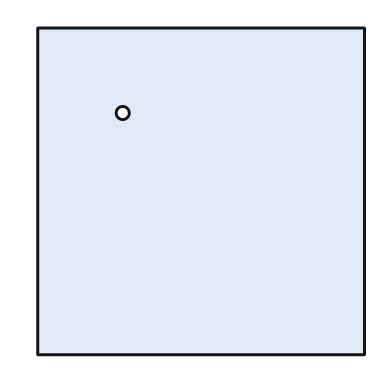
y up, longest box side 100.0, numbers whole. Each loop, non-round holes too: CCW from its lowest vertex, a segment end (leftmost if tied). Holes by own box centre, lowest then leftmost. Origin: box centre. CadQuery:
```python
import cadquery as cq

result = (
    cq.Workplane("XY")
    .moveTo(-50.0, -50.0)
    .lineTo(50.0, -50.0)
    .lineTo(50.0, 50.0)
    .lineTo(-50.0, 50.0)
    .close()
    .moveTo(-24.0, 24.0)
    .circle(2.0)
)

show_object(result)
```